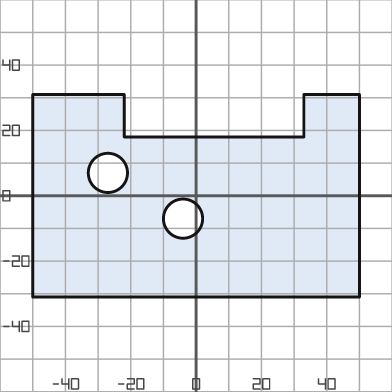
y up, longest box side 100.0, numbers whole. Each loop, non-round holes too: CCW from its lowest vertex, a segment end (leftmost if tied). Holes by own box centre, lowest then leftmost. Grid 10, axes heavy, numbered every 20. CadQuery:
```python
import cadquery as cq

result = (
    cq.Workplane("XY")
    .moveTo(-50.0, -31.0)
    .lineTo(50.0, -31.0)
    .lineTo(50.0, 31.0)
    .lineTo(33.0, 31.0)
    .lineTo(33.0, 18.0)
    .lineTo(-22.0, 18.0)
    .lineTo(-22.0, 31.0)
    .lineTo(-50.0, 31.0)
    .close()
    .moveTo(-4.0, -7.0)
    .circle(6.0)
    .moveTo(-27.0, 7.0)
    .circle(6.0)
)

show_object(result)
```